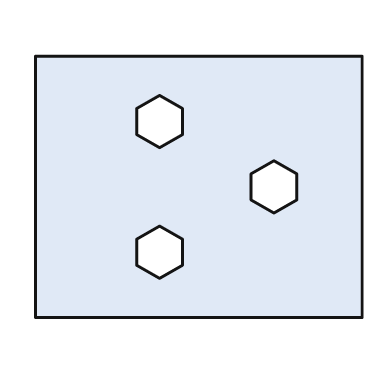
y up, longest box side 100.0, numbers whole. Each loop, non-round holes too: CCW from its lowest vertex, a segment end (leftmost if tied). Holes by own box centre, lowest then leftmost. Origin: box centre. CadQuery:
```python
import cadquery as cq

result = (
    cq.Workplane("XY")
    .moveTo(-50.0, -40.0)
    .lineTo(50.0, -40.0)
    .lineTo(50.0, 40.0)
    .lineTo(-50.0, 40.0)
    .close()
    .moveTo(-12.0, -28.0)
    .lineTo(-5.0, -24.0)
    .lineTo(-5.0, -16.0)
    .lineTo(-12.0, -12.0)
    .lineTo(-19.0, -16.0)
    .lineTo(-19.0, -24.0)
    .close()
    .moveTo(23.0, -8.0)
    .lineTo(30.0, -4.0)
    .lineTo(30.0, 4.0)
    .lineTo(23.0, 8.0)
    .lineTo(16.0, 4.0)
    .lineTo(16.0, -4.0)
    .close()
    .moveTo(-12.0, 12.0)
    .lineTo(-5.0, 16.0)
    .lineTo(-5.0, 24.0)
    .lineTo(-12.0, 28.0)
    .lineTo(-19.0, 24.0)
    .lineTo(-19.0, 16.0)
    .close()
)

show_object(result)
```